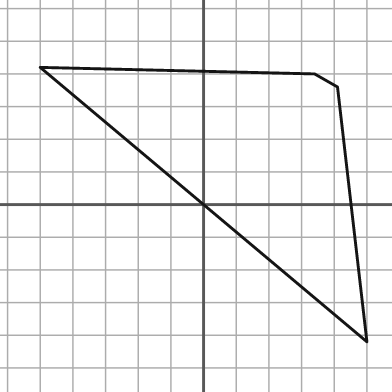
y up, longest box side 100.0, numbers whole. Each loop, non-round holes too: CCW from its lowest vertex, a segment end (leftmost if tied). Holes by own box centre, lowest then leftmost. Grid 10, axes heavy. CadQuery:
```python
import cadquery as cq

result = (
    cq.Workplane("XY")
    .moveTo(50.0, -42.0)
    .lineTo(41.0, 36.0)
    .lineTo(34.0, 40.0)
    .lineTo(-50.0, 42.0)
    .close()
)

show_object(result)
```